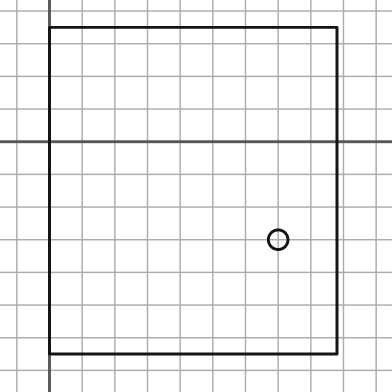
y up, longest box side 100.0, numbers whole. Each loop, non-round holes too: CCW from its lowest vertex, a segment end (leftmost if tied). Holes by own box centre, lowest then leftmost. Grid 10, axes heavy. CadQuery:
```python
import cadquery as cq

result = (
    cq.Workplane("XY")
    .moveTo(0.0, -65.0)
    .lineTo(88.0, -65.0)
    .lineTo(88.0, 35.0)
    .lineTo(0.0, 35.0)
    .close()
    .moveTo(70.0, -30.0)
    .circle(3.0)
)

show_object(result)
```